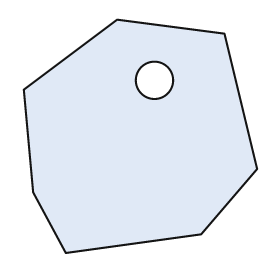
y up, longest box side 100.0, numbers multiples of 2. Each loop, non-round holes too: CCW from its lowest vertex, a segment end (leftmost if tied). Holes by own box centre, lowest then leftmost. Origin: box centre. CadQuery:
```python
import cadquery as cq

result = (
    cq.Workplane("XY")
    .moveTo(-32.0, -50.0)
    .lineTo(26.0, -42.0)
    .lineTo(50.0, -14.0)
    .lineTo(36.0, 44.0)
    .lineTo(-10.0, 50.0)
    .lineTo(-50.0, 20.0)
    .lineTo(-46.0, -24.0)
    .close()
    .moveTo(6.0, 24.0)
    .circle(8.0)
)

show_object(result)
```